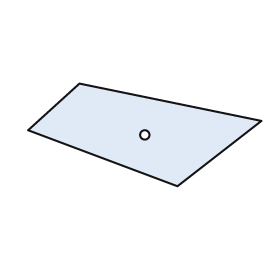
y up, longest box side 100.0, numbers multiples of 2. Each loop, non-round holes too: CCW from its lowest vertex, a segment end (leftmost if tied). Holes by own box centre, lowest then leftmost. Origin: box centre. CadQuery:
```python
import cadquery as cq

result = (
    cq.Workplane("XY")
    .moveTo(14.0, -22.0)
    .lineTo(50.0, 6.0)
    .lineTo(-28.0, 22.0)
    .lineTo(-50.0, 2.0)
    .close()
    .moveTo(0.0, 0.0)
    .circle(2.0)
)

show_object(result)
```